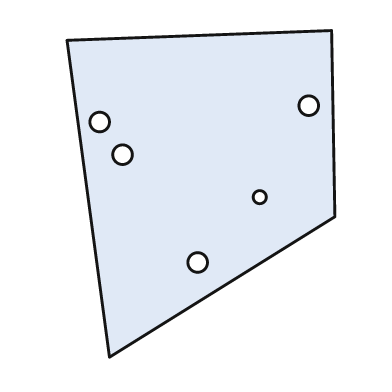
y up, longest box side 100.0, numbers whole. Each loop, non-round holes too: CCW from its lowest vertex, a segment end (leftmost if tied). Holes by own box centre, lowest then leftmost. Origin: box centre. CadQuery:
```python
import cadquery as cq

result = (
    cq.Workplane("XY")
    .moveTo(-28.0, -50.0)
    .lineTo(41.0, -7.0)
    .lineTo(40.0, 50.0)
    .lineTo(-41.0, 47.0)
    .close()
    .moveTo(-1.0, -21.0)
    .circle(3.0)
    .moveTo(18.0, -1.0)
    .circle(2.0)
    .moveTo(-24.0, 12.0)
    .circle(3.0)
    .moveTo(-31.0, 22.0)
    .circle(3.0)
    .moveTo(33.0, 27.0)
    .circle(3.0)
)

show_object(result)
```